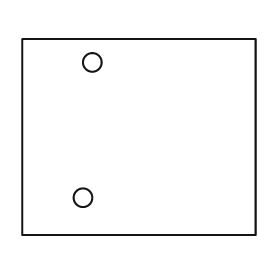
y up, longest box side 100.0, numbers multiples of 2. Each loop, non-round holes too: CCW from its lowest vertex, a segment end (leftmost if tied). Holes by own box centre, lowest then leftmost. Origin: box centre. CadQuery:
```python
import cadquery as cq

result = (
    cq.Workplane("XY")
    .moveTo(-50.0, -42.0)
    .lineTo(50.0, -42.0)
    .lineTo(50.0, 42.0)
    .lineTo(-50.0, 42.0)
    .close()
    .moveTo(-24.0, -26.0)
    .circle(4.0)
    .moveTo(-20.0, 32.0)
    .circle(4.0)
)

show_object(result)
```